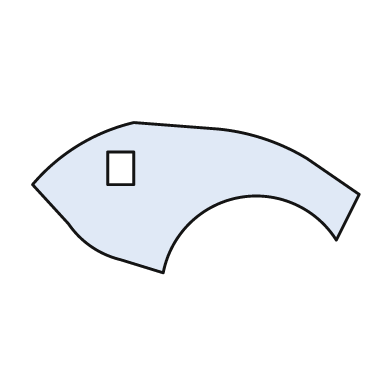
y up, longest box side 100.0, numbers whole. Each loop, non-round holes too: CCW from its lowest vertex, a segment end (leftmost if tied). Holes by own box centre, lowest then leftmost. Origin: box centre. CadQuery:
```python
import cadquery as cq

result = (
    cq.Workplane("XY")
    .moveTo(-10.0, -23.0)
    .threePointArc((13.0, 0.0), (43.0, -13.0))
    .lineTo(50.0, 1.0)
    .lineTo(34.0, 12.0)
    .threePointArc((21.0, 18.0), (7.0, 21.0))
    .lineTo(-19.0, 23.0)
    .threePointArc((-36.0, 16.0), (-50.0, 4.0))
    .lineTo(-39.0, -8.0)
    .threePointArc((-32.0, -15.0), (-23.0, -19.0))
    .close()
    .moveTo(-27.0, 4.0)
    .lineTo(-19.0, 4.0)
    .lineTo(-19.0, 14.0)
    .lineTo(-27.0, 14.0)
    .close()
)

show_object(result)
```